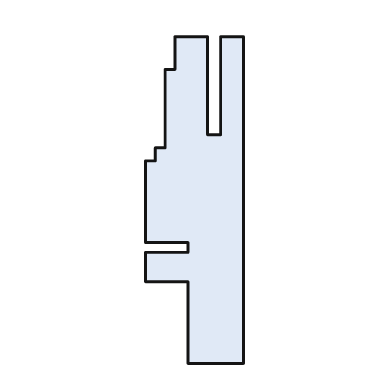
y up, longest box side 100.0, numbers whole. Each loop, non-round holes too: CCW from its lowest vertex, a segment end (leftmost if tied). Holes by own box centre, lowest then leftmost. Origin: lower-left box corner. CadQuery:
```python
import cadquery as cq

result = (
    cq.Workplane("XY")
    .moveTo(13.0, 0.0)
    .lineTo(30.0, 0.0)
    .lineTo(30.0, 100.0)
    .lineTo(23.0, 100.0)
    .lineTo(23.0, 70.0)
    .lineTo(19.0, 70.0)
    .lineTo(19.0, 100.0)
    .lineTo(9.0, 100.0)
    .lineTo(9.0, 90.0)
    .lineTo(6.0, 90.0)
    .lineTo(6.0, 66.0)
    .lineTo(3.0, 66.0)
    .lineTo(3.0, 62.0)
    .lineTo(0.0, 62.0)
    .lineTo(0.0, 37.0)
    .lineTo(13.0, 37.0)
    .lineTo(13.0, 34.0)
    .lineTo(0.0, 34.0)
    .lineTo(0.0, 25.0)
    .lineTo(13.0, 25.0)
    .close()
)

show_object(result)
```